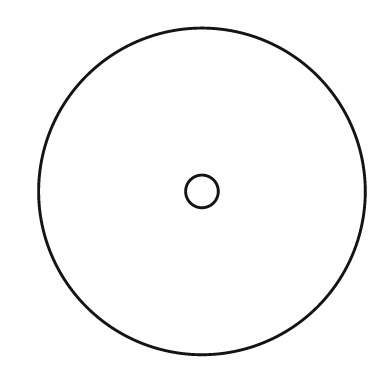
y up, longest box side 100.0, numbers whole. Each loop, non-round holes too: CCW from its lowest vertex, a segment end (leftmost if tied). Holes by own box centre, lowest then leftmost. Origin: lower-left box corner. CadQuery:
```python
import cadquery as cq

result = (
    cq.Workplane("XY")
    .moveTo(50.0, 50.0)
    .circle(50.0)
    .moveTo(50.0, 50.0)
    .circle(5.0)
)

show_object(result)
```